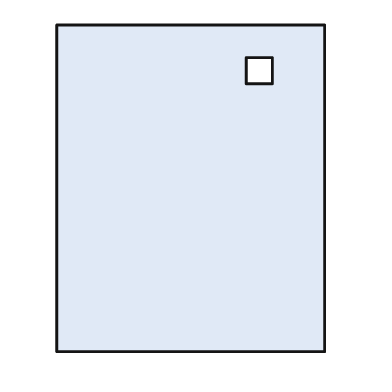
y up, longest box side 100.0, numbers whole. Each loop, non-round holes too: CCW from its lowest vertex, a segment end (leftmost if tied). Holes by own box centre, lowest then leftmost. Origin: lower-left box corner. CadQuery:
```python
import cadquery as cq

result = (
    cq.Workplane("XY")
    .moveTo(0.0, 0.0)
    .lineTo(82.0, 0.0)
    .lineTo(82.0, 100.0)
    .lineTo(0.0, 100.0)
    .close()
    .moveTo(58.0, 82.0)
    .lineTo(66.0, 82.0)
    .lineTo(66.0, 90.0)
    .lineTo(58.0, 90.0)
    .close()
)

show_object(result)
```